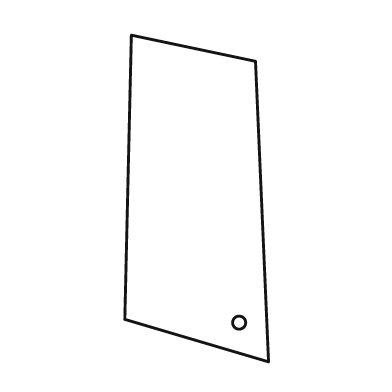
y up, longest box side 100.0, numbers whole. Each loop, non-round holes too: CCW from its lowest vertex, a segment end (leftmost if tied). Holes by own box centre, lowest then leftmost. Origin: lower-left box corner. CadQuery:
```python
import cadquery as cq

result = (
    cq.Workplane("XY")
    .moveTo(44.0, 0.0)
    .lineTo(40.0, 92.0)
    .lineTo(2.0, 100.0)
    .lineTo(0.0, 13.0)
    .close()
    .moveTo(35.0, 12.0)
    .circle(2.0)
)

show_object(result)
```